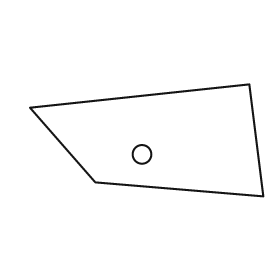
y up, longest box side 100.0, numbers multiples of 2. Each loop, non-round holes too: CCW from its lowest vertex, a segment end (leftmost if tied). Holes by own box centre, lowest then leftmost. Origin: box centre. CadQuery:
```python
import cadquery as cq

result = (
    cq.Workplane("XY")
    .moveTo(50.0, -24.0)
    .lineTo(44.0, 24.0)
    .lineTo(-50.0, 14.0)
    .lineTo(-22.0, -18.0)
    .close()
    .moveTo(-2.0, -6.0)
    .circle(4.0)
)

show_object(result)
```